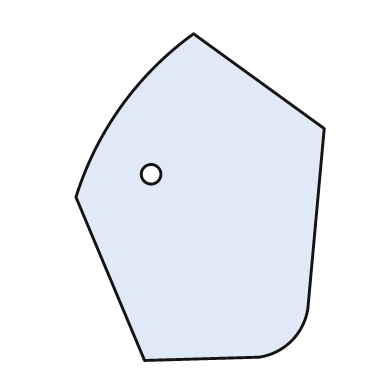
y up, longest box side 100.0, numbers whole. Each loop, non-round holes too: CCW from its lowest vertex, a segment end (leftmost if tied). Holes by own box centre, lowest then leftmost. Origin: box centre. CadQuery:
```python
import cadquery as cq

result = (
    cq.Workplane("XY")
    .moveTo(-17.0, -50.0)
    .lineTo(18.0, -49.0)
    .threePointArc((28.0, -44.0), (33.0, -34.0))
    .lineTo(38.0, 21.0)
    .lineTo(-2.0, 50.0)
    .threePointArc((-24.0, 28.0), (-38.0, 0.0))
    .close()
    .moveTo(-15.0, 7.0)
    .circle(3.0)
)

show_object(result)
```